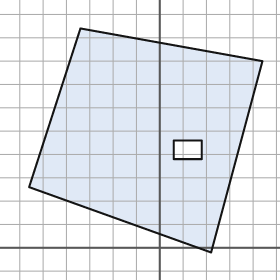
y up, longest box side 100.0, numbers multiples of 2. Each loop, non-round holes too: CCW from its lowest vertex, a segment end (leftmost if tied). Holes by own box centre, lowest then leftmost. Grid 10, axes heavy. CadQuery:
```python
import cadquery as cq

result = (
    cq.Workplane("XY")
    .moveTo(22.0, -2.0)
    .lineTo(44.0, 80.0)
    .lineTo(-34.0, 94.0)
    .lineTo(-56.0, 26.0)
    .close()
    .moveTo(6.0, 38.0)
    .lineTo(18.0, 38.0)
    .lineTo(18.0, 46.0)
    .lineTo(6.0, 46.0)
    .close()
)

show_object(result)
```